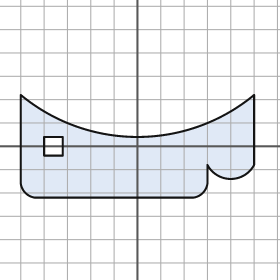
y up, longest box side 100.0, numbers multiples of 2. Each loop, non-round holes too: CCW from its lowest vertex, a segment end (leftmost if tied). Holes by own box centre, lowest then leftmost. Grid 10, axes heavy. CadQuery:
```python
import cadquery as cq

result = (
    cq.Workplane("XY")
    .moveTo(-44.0, -22.0)
    .lineTo(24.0, -22.0)
    .threePointArc((28.0, -20.0), (30.0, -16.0))
    .lineTo(30.0, -8.0)
    .threePointArc((40.0, -14.0), (50.0, -8.0))
    .lineTo(50.0, 22.0)
    .threePointArc((0.0, 4.0), (-50.0, 22.0))
    .lineTo(-50.0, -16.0)
    .threePointArc((-48.0, -20.0), (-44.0, -22.0))
    .close()
    .moveTo(-40.0, -4.0)
    .lineTo(-32.0, -4.0)
    .lineTo(-32.0, 4.0)
    .lineTo(-40.0, 4.0)
    .close()
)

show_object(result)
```